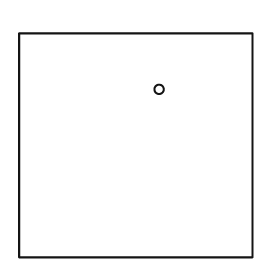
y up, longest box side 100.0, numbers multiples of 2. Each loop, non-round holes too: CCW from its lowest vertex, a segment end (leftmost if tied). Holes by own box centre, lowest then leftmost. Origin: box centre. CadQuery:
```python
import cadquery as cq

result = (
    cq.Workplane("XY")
    .moveTo(-50.0, -48.0)
    .lineTo(50.0, -48.0)
    .lineTo(50.0, 48.0)
    .lineTo(-50.0, 48.0)
    .close()
    .moveTo(10.0, 24.0)
    .circle(2.0)
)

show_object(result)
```